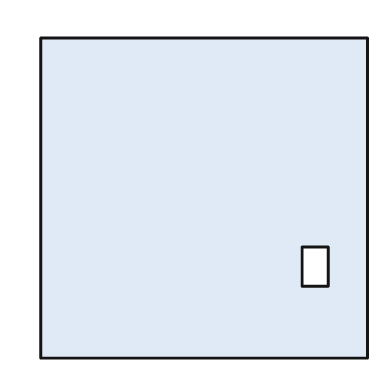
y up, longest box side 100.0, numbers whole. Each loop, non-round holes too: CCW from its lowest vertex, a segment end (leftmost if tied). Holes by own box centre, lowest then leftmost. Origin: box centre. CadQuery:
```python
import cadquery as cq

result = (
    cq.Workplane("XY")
    .moveTo(-50.0, -49.0)
    .lineTo(50.0, -49.0)
    .lineTo(50.0, 49.0)
    .lineTo(-50.0, 49.0)
    .close()
    .moveTo(30.0, -27.0)
    .lineTo(38.0, -27.0)
    .lineTo(38.0, -15.0)
    .lineTo(30.0, -15.0)
    .close()
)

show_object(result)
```